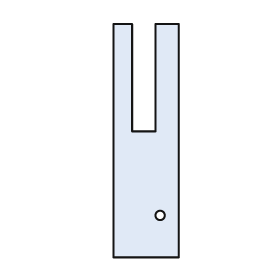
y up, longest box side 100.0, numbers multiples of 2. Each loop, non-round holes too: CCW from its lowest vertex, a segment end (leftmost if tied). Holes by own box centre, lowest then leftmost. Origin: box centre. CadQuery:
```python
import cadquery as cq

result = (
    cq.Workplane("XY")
    .moveTo(-14.0, -50.0)
    .lineTo(14.0, -50.0)
    .lineTo(14.0, 50.0)
    .lineTo(4.0, 50.0)
    .lineTo(4.0, 4.0)
    .lineTo(-6.0, 4.0)
    .lineTo(-6.0, 50.0)
    .lineTo(-14.0, 50.0)
    .close()
    .moveTo(6.0, -32.0)
    .circle(2.0)
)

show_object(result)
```